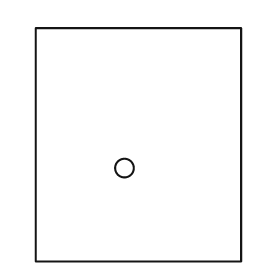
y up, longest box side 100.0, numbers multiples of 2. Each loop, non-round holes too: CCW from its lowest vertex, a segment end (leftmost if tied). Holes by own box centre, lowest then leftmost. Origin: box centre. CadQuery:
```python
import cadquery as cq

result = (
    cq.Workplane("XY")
    .moveTo(-44.0, -50.0)
    .lineTo(44.0, -50.0)
    .lineTo(44.0, 50.0)
    .lineTo(-44.0, 50.0)
    .close()
    .moveTo(-6.0, -10.0)
    .circle(4.0)
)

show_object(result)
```